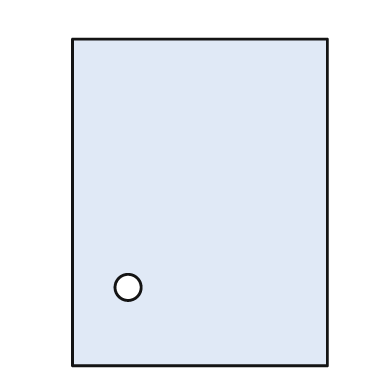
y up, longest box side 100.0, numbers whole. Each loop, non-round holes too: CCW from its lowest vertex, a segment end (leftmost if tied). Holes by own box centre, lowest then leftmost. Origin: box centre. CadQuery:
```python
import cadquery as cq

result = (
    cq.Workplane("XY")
    .moveTo(-39.0, -50.0)
    .lineTo(39.0, -50.0)
    .lineTo(39.0, 50.0)
    .lineTo(-39.0, 50.0)
    .close()
    .moveTo(-22.0, -26.0)
    .circle(4.0)
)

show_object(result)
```